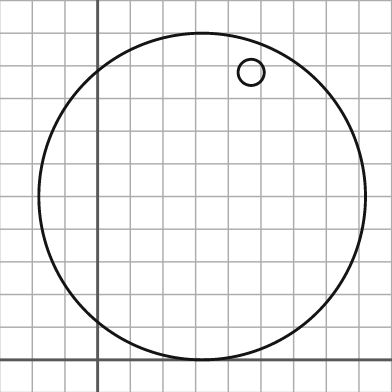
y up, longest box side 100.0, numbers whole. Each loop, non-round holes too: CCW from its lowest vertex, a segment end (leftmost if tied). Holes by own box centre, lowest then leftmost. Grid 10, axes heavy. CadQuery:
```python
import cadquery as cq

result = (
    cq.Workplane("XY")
    .moveTo(32.0, 50.0)
    .circle(50.0)
    .moveTo(47.0, 88.0)
    .circle(4.0)
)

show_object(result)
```